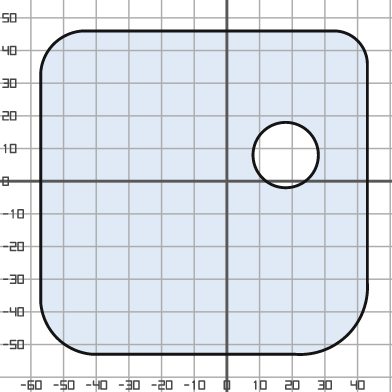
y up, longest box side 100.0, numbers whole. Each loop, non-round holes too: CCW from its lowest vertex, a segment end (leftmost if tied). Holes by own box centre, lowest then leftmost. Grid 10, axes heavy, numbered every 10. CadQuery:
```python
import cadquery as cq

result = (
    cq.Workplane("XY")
    .moveTo(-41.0, -53.0)
    .lineTo(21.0, -53.0)
    .threePointArc((37.0, -47.0), (43.0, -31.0))
    .lineTo(43.0, 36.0)
    .threePointArc((40.0, 43.0), (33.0, 46.0))
    .lineTo(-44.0, 46.0)
    .threePointArc((-53.0, 42.0), (-57.0, 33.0))
    .lineTo(-57.0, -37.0)
    .threePointArc((-52.0, -48.0), (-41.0, -53.0))
    .close()
    .moveTo(18.0, 8.0)
    .circle(10.0)
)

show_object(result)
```